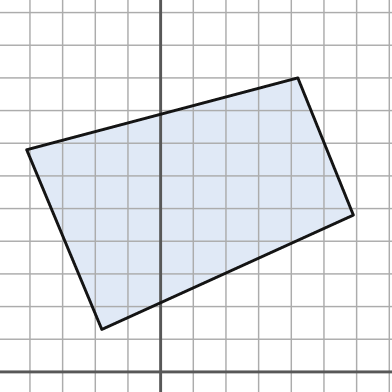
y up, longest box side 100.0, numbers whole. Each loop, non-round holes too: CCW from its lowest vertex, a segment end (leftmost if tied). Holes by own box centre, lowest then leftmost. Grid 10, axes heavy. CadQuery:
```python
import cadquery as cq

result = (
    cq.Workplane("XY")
    .moveTo(-18.0, 13.0)
    .lineTo(59.0, 48.0)
    .lineTo(42.0, 90.0)
    .lineTo(-41.0, 68.0)
    .close()
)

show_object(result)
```